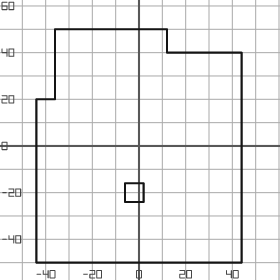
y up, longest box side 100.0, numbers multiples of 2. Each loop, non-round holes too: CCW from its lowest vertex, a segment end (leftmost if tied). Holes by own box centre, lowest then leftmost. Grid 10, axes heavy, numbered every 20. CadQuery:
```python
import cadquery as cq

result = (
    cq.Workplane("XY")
    .moveTo(-44.0, -50.0)
    .lineTo(44.0, -50.0)
    .lineTo(44.0, 40.0)
    .lineTo(12.0, 40.0)
    .lineTo(12.0, 50.0)
    .lineTo(-36.0, 50.0)
    .lineTo(-36.0, 20.0)
    .lineTo(-44.0, 20.0)
    .close()
    .moveTo(-6.0, -24.0)
    .lineTo(2.0, -24.0)
    .lineTo(2.0, -16.0)
    .lineTo(-6.0, -16.0)
    .close()
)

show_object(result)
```